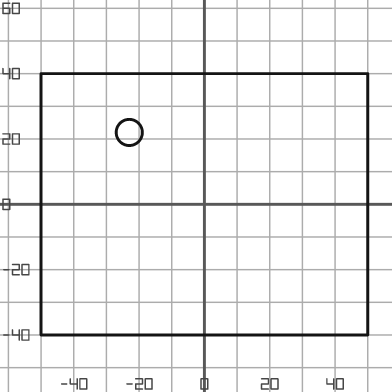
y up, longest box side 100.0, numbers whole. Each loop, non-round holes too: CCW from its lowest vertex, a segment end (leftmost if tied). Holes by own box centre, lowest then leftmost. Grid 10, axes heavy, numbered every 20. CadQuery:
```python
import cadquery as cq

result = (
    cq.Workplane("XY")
    .moveTo(-50.0, -40.0)
    .lineTo(50.0, -40.0)
    .lineTo(50.0, 40.0)
    .lineTo(-50.0, 40.0)
    .close()
    .moveTo(-23.0, 22.0)
    .circle(4.0)
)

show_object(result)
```